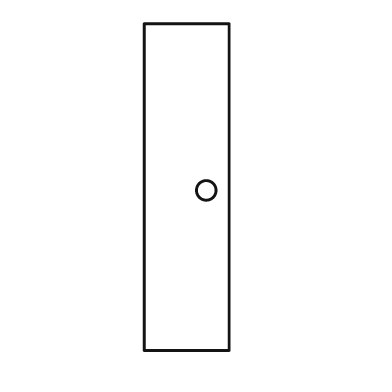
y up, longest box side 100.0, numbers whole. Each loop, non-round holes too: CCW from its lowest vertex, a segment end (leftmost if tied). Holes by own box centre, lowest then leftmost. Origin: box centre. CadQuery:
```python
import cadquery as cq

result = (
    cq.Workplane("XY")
    .moveTo(-13.0, -50.0)
    .lineTo(13.0, -50.0)
    .lineTo(13.0, 50.0)
    .lineTo(-13.0, 50.0)
    .close()
    .moveTo(6.0, -1.0)
    .circle(3.0)
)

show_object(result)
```